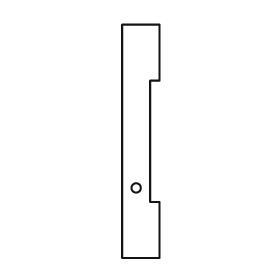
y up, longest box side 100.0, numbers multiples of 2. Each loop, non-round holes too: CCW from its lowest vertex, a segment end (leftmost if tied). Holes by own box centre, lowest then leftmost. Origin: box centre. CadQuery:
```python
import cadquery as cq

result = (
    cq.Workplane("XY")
    .moveTo(-8.0, -50.0)
    .lineTo(8.0, -50.0)
    .lineTo(8.0, -26.0)
    .lineTo(4.0, -26.0)
    .lineTo(4.0, 26.0)
    .lineTo(8.0, 26.0)
    .lineTo(8.0, 50.0)
    .lineTo(-8.0, 50.0)
    .close()
    .moveTo(-2.0, -20.0)
    .circle(2.0)
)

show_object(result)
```